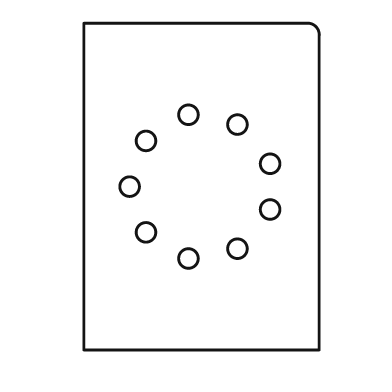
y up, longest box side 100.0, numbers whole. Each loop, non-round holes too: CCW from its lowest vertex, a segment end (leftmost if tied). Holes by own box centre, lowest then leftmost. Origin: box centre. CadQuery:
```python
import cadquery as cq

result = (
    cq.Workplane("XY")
    .moveTo(-36.0, -50.0)
    .lineTo(36.0, -50.0)
    .lineTo(36.0, 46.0)
    .threePointArc((35.0, 49.0), (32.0, 50.0))
    .lineTo(-36.0, 50.0)
    .close()
    .moveTo(-4.0, -22.0)
    .circle(3.0)
    .moveTo(11.0, -19.0)
    .circle(3.0)
    .moveTo(-17.0, -14.0)
    .circle(3.0)
    .moveTo(21.0, -7.0)
    .circle(3.0)
    .moveTo(-22.0, 0.0)
    .circle(3.0)
    .moveTo(21.0, 7.0)
    .circle(3.0)
    .moveTo(-17.0, 14.0)
    .circle(3.0)
    .moveTo(11.0, 19.0)
    .circle(3.0)
    .moveTo(-4.0, 22.0)
    .circle(3.0)
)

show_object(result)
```